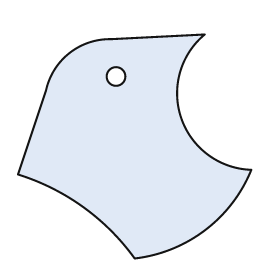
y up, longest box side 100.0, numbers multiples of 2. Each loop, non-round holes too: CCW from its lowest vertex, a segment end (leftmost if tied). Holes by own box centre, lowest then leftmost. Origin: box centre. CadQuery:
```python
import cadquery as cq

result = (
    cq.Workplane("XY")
    .moveTo(0.0, -48.0)
    .threePointArc((30.0, -36.0), (50.0, -10.0))
    .threePointArc((20.0, 12.0), (30.0, 48.0))
    .lineTo(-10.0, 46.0)
    .threePointArc((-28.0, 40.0), (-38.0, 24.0))
    .lineTo(-50.0, -12.0)
    .threePointArc((-22.0, -26.0), (0.0, -48.0))
    .close()
    .moveTo(-8.0, 30.0)
    .circle(4.0)
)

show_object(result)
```